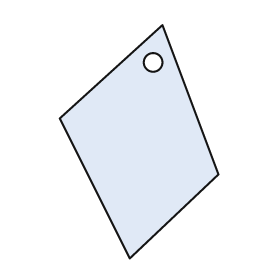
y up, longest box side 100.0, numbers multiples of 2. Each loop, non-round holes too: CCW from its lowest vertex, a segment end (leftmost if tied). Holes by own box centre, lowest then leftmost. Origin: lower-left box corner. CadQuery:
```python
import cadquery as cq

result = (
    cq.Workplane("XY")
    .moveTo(30.0, 0.0)
    .lineTo(68.0, 36.0)
    .lineTo(44.0, 100.0)
    .lineTo(0.0, 60.0)
    .close()
    .moveTo(40.0, 84.0)
    .circle(4.0)
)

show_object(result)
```